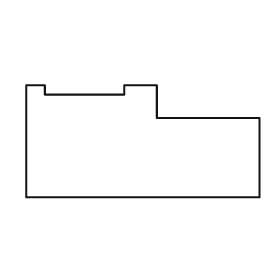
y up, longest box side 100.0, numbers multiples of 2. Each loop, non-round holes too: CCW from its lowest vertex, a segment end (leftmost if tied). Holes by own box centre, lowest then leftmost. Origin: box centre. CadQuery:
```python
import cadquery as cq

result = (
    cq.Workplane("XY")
    .moveTo(-50.0, -24.0)
    .lineTo(50.0, -24.0)
    .lineTo(50.0, 10.0)
    .lineTo(6.0, 10.0)
    .lineTo(6.0, 24.0)
    .lineTo(-8.0, 24.0)
    .lineTo(-8.0, 20.0)
    .lineTo(-42.0, 20.0)
    .lineTo(-42.0, 24.0)
    .lineTo(-50.0, 24.0)
    .close()
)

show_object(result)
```